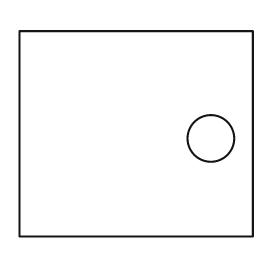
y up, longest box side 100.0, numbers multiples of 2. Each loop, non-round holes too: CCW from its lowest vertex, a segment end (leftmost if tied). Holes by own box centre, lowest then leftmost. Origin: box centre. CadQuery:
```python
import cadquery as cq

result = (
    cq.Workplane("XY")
    .moveTo(-50.0, -44.0)
    .lineTo(50.0, -44.0)
    .lineTo(50.0, 44.0)
    .lineTo(-50.0, 44.0)
    .close()
    .moveTo(32.0, -2.0)
    .circle(10.0)
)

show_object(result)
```